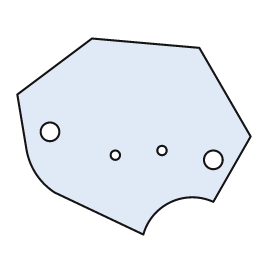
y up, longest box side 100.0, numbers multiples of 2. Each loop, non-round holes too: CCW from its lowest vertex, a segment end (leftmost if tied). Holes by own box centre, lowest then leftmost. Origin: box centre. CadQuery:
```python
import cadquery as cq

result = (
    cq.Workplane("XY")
    .moveTo(4.0, -42.0)
    .threePointArc((16.0, -28.0), (34.0, -28.0))
    .lineTo(50.0, 0.0)
    .lineTo(28.0, 38.0)
    .lineTo(-18.0, 42.0)
    .lineTo(-50.0, 18.0)
    .lineTo(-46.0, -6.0)
    .threePointArc((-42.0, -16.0), (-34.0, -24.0))
    .close()
    .moveTo(34.0, -10.0)
    .circle(4.0)
    .moveTo(-8.0, -8.0)
    .circle(2.0)
    .moveTo(12.0, -6.0)
    .circle(2.0)
    .moveTo(-36.0, 2.0)
    .circle(4.0)
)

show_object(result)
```